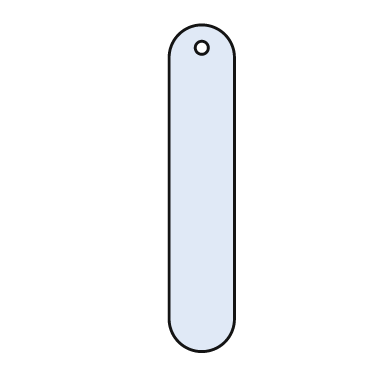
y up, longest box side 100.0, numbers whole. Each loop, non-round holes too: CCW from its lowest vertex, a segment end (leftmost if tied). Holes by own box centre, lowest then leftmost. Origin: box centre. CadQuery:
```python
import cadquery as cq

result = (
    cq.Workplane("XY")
    .moveTo(-10.0, -40.0)
    .threePointArc((0.0, -50.0), (10.0, -40.0))
    .lineTo(10.0, 40.0)
    .threePointArc((0.0, 50.0), (-10.0, 40.0))
    .close()
    .moveTo(0.0, 43.0)
    .circle(2.0)
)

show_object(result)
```